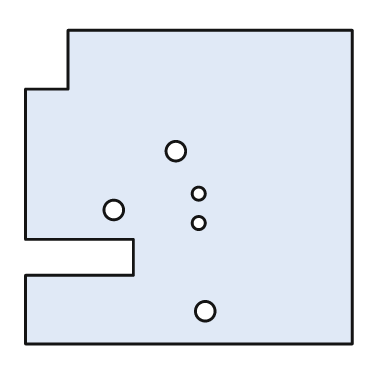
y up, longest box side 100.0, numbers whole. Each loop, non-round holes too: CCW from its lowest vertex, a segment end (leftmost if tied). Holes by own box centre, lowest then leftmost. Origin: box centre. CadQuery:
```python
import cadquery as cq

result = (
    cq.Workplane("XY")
    .moveTo(-50.0, -48.0)
    .lineTo(50.0, -48.0)
    .lineTo(50.0, 48.0)
    .lineTo(-37.0, 48.0)
    .lineTo(-37.0, 30.0)
    .lineTo(-50.0, 30.0)
    .lineTo(-50.0, -16.0)
    .lineTo(-17.0, -16.0)
    .lineTo(-17.0, -27.0)
    .lineTo(-50.0, -27.0)
    .close()
    .moveTo(5.0, -38.0)
    .circle(3.0)
    .moveTo(3.0, -11.0)
    .circle(2.0)
    .moveTo(-23.0, -7.0)
    .circle(3.0)
    .moveTo(3.0, -2.0)
    .circle(2.0)
    .moveTo(-4.0, 11.0)
    .circle(3.0)
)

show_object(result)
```